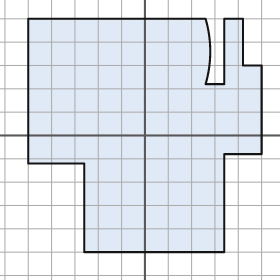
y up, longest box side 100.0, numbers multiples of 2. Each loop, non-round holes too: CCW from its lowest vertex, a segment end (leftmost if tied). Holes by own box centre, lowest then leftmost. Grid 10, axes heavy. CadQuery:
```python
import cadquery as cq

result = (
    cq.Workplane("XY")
    .moveTo(-26.0, -50.0)
    .lineTo(34.0, -50.0)
    .lineTo(34.0, -8.0)
    .lineTo(50.0, -8.0)
    .lineTo(50.0, 30.0)
    .lineTo(42.0, 30.0)
    .lineTo(42.0, 50.0)
    .lineTo(34.0, 50.0)
    .lineTo(34.0, 22.0)
    .lineTo(26.0, 22.0)
    .threePointArc((28.0, 36.0), (26.0, 50.0))
    .lineTo(-50.0, 50.0)
    .lineTo(-50.0, -12.0)
    .lineTo(-26.0, -12.0)
    .close()
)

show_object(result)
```